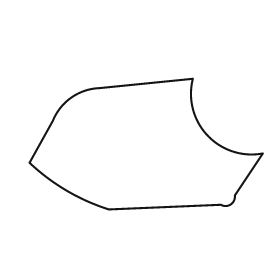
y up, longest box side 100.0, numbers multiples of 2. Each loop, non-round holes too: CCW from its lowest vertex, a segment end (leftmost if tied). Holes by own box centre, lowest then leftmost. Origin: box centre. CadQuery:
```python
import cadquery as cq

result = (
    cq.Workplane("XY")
    .moveTo(-16.0, -28.0)
    .lineTo(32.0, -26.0)
    .threePointArc((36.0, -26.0), (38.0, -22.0))
    .lineTo(50.0, -4.0)
    .threePointArc((26.0, 4.0), (20.0, 28.0))
    .lineTo(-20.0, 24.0)
    .threePointArc((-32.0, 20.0), (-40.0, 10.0))
    .lineTo(-50.0, -8.0)
    .threePointArc((-34.0, -20.0), (-16.0, -28.0))
    .close()
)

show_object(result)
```